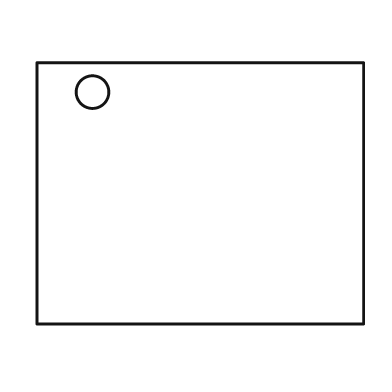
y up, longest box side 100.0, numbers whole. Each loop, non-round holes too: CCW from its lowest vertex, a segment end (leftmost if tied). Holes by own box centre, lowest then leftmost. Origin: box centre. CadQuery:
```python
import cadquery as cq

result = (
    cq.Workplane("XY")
    .moveTo(-50.0, -40.0)
    .lineTo(50.0, -40.0)
    .lineTo(50.0, 40.0)
    .lineTo(-50.0, 40.0)
    .close()
    .moveTo(-33.0, 31.0)
    .circle(5.0)
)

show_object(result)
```